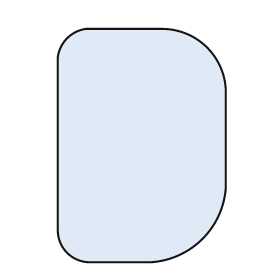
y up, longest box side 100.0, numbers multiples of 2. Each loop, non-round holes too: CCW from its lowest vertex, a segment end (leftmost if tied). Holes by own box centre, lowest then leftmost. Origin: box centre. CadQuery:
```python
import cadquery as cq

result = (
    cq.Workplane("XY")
    .moveTo(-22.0, -50.0)
    .lineTo(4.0, -50.0)
    .threePointArc((26.0, -40.0), (36.0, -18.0))
    .lineTo(36.0, 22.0)
    .threePointArc((28.0, 42.0), (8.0, 50.0))
    .lineTo(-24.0, 50.0)
    .threePointArc((-32.0, 46.0), (-36.0, 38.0))
    .lineTo(-36.0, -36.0)
    .threePointArc((-32.0, -46.0), (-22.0, -50.0))
    .close()
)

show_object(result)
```